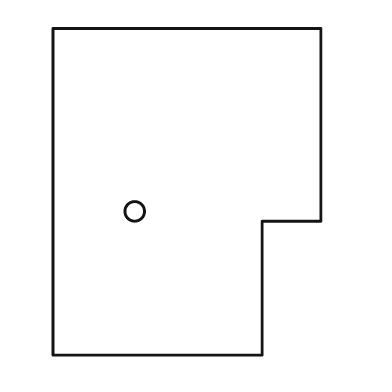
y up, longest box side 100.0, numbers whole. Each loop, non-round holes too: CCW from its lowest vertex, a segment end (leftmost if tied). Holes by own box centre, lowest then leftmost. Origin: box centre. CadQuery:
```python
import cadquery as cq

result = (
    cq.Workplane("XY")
    .moveTo(-41.0, -50.0)
    .lineTo(23.0, -50.0)
    .lineTo(23.0, -9.0)
    .lineTo(41.0, -9.0)
    .lineTo(41.0, 50.0)
    .lineTo(-41.0, 50.0)
    .close()
    .moveTo(-16.0, -6.0)
    .circle(3.0)
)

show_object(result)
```